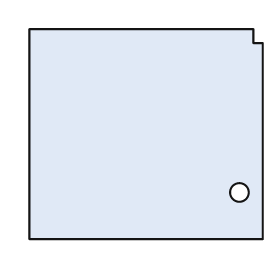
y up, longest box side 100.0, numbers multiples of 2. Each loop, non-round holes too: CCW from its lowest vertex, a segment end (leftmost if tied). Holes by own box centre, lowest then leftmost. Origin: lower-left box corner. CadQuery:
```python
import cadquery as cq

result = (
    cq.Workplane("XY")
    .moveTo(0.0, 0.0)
    .lineTo(100.0, 0.0)
    .lineTo(100.0, 84.0)
    .lineTo(96.0, 84.0)
    .lineTo(96.0, 90.0)
    .lineTo(0.0, 90.0)
    .close()
    .moveTo(90.0, 20.0)
    .circle(4.0)
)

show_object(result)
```